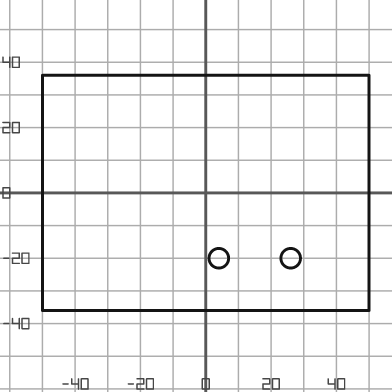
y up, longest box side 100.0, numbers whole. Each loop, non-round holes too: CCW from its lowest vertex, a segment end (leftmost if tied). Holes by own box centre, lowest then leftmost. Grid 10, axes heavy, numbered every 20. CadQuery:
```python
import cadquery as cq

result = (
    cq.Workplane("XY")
    .moveTo(-50.0, -36.0)
    .lineTo(50.0, -36.0)
    .lineTo(50.0, 36.0)
    .lineTo(-50.0, 36.0)
    .close()
    .moveTo(4.0, -20.0)
    .circle(3.0)
    .moveTo(26.0, -20.0)
    .circle(3.0)
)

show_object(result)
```